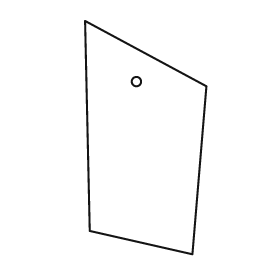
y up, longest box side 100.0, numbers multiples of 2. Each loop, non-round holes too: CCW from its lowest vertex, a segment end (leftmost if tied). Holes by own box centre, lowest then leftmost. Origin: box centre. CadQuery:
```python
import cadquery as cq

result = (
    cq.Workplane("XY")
    .moveTo(20.0, -50.0)
    .lineTo(26.0, 22.0)
    .lineTo(-26.0, 50.0)
    .lineTo(-24.0, -40.0)
    .close()
    .moveTo(-4.0, 24.0)
    .circle(2.0)
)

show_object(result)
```